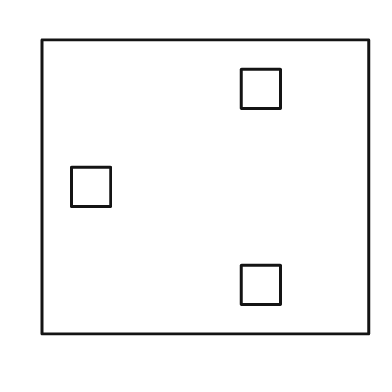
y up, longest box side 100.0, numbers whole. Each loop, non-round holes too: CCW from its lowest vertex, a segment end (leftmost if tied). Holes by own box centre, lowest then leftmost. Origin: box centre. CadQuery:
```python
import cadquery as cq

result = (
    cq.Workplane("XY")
    .moveTo(-50.0, -45.0)
    .lineTo(50.0, -45.0)
    .lineTo(50.0, 45.0)
    .lineTo(-50.0, 45.0)
    .close()
    .moveTo(11.0, -36.0)
    .lineTo(23.0, -36.0)
    .lineTo(23.0, -24.0)
    .lineTo(11.0, -24.0)
    .close()
    .moveTo(-41.0, -6.0)
    .lineTo(-29.0, -6.0)
    .lineTo(-29.0, 6.0)
    .lineTo(-41.0, 6.0)
    .close()
    .moveTo(11.0, 24.0)
    .lineTo(23.0, 24.0)
    .lineTo(23.0, 36.0)
    .lineTo(11.0, 36.0)
    .close()
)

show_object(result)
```